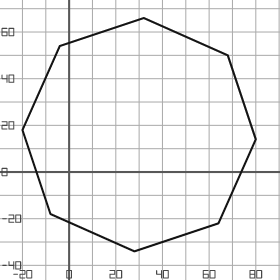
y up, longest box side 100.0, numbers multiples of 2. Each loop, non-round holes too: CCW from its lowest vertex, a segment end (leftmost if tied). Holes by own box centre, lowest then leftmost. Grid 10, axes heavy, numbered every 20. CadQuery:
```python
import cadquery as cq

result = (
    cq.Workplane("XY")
    .moveTo(28.0, -34.0)
    .lineTo(64.0, -22.0)
    .lineTo(80.0, 14.0)
    .lineTo(68.0, 50.0)
    .lineTo(32.0, 66.0)
    .lineTo(-4.0, 54.0)
    .lineTo(-20.0, 18.0)
    .lineTo(-8.0, -18.0)
    .close()
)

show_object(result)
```